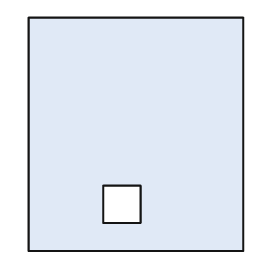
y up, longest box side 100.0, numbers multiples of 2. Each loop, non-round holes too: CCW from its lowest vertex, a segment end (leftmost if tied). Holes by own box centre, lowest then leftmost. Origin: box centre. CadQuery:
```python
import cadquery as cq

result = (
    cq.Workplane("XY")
    .moveTo(-46.0, -50.0)
    .lineTo(46.0, -50.0)
    .lineTo(46.0, 50.0)
    .lineTo(-46.0, 50.0)
    .close()
    .moveTo(-14.0, -38.0)
    .lineTo(2.0, -38.0)
    .lineTo(2.0, -22.0)
    .lineTo(-14.0, -22.0)
    .close()
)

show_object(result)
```